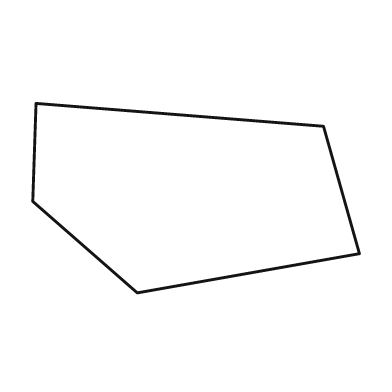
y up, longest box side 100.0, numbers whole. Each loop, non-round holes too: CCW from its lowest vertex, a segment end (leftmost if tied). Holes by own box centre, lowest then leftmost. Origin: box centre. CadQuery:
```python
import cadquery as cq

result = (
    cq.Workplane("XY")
    .moveTo(-18.0, -29.0)
    .lineTo(50.0, -17.0)
    .lineTo(39.0, 22.0)
    .lineTo(-49.0, 29.0)
    .lineTo(-50.0, -1.0)
    .close()
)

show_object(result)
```